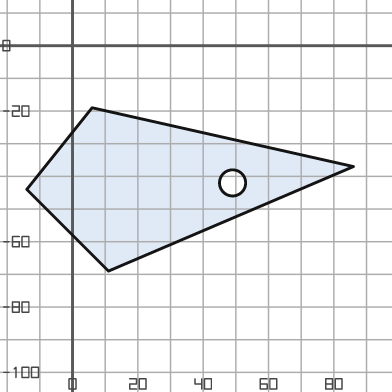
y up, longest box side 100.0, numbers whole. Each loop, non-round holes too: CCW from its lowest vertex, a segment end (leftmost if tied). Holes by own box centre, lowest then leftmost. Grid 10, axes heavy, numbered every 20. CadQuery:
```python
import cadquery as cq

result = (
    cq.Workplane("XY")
    .moveTo(11.0, -69.0)
    .lineTo(86.0, -37.0)
    .lineTo(6.0, -19.0)
    .lineTo(-14.0, -44.0)
    .close()
    .moveTo(49.0, -42.0)
    .circle(4.0)
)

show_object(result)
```